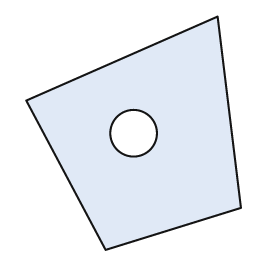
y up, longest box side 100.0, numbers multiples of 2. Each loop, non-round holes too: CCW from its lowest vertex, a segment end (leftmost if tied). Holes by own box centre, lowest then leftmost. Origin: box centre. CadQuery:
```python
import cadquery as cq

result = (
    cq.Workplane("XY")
    .moveTo(-12.0, -50.0)
    .lineTo(46.0, -32.0)
    .lineTo(36.0, 50.0)
    .lineTo(-46.0, 14.0)
    .close()
    .moveTo(0.0, 0.0)
    .circle(10.0)
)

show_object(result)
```